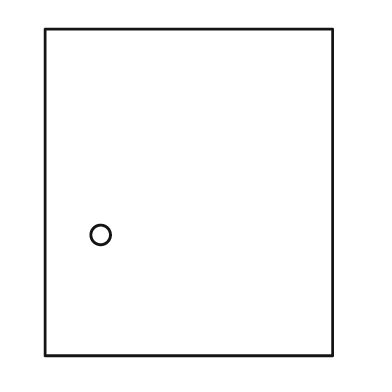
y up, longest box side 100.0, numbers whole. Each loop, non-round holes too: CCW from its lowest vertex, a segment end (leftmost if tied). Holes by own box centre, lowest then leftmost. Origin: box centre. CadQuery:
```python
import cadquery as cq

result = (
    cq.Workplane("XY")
    .moveTo(-44.0, -50.0)
    .lineTo(44.0, -50.0)
    .lineTo(44.0, 50.0)
    .lineTo(-44.0, 50.0)
    .close()
    .moveTo(-27.0, -13.0)
    .circle(3.0)
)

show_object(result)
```